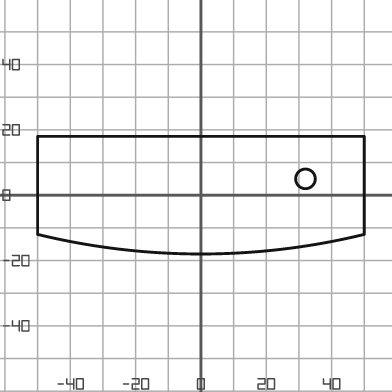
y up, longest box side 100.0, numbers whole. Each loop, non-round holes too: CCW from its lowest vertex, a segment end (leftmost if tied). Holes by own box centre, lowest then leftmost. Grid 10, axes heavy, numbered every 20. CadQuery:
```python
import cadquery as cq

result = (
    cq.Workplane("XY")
    .moveTo(-50.0, -12.0)
    .threePointArc((0.0, -18.0), (50.0, -12.0))
    .lineTo(50.0, 18.0)
    .lineTo(-50.0, 18.0)
    .close()
    .moveTo(32.0, 5.0)
    .circle(3.0)
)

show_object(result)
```